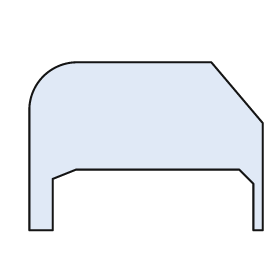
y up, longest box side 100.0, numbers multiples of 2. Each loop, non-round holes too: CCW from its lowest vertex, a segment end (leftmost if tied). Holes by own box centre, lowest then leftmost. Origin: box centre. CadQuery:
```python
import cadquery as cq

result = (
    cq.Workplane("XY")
    .moveTo(-50.0, -36.0)
    .lineTo(-40.0, -36.0)
    .lineTo(-40.0, -14.0)
    .lineTo(-30.0, -10.0)
    .lineTo(40.0, -10.0)
    .lineTo(46.0, -16.0)
    .lineTo(46.0, -36.0)
    .lineTo(50.0, -36.0)
    .lineTo(50.0, 10.0)
    .lineTo(28.0, 36.0)
    .lineTo(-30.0, 36.0)
    .threePointArc((-44.0, 30.0), (-50.0, 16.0))
    .close()
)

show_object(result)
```